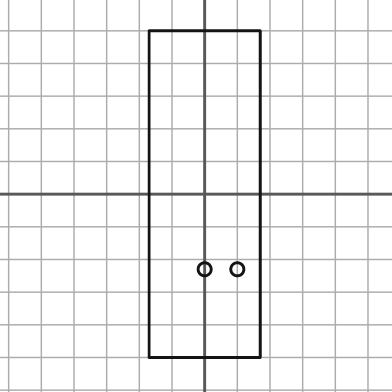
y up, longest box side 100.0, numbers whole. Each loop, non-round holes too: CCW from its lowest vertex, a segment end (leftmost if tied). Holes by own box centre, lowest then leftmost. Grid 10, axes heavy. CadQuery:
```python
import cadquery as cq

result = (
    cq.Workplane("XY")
    .moveTo(-17.0, -50.0)
    .lineTo(17.0, -50.0)
    .lineTo(17.0, 50.0)
    .lineTo(-17.0, 50.0)
    .close()
    .moveTo(0.0, -23.0)
    .circle(2.0)
    .moveTo(10.0, -23.0)
    .circle(2.0)
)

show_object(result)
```